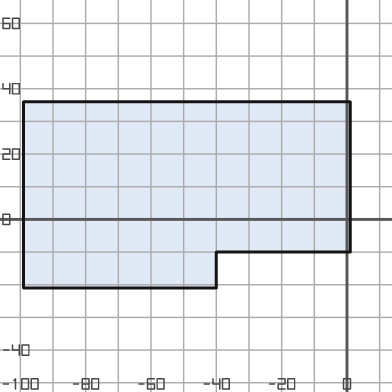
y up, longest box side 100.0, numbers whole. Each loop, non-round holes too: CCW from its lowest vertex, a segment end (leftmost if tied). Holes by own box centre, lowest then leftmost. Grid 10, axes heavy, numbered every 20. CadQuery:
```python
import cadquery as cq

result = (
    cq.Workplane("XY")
    .moveTo(-99.0, -21.0)
    .lineTo(-40.0, -21.0)
    .lineTo(-40.0, -10.0)
    .lineTo(1.0, -10.0)
    .lineTo(1.0, 36.0)
    .lineTo(-99.0, 36.0)
    .close()
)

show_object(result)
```